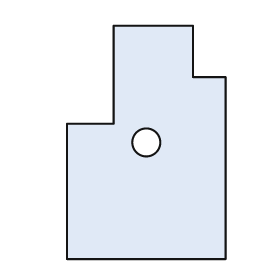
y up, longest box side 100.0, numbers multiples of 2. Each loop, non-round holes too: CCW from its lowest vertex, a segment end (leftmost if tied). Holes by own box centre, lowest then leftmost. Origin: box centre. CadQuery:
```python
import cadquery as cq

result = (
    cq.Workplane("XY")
    .moveTo(-34.0, -50.0)
    .lineTo(34.0, -50.0)
    .lineTo(34.0, 28.0)
    .lineTo(20.0, 28.0)
    .lineTo(20.0, 50.0)
    .lineTo(-14.0, 50.0)
    .lineTo(-14.0, 8.0)
    .lineTo(-34.0, 8.0)
    .close()
    .moveTo(0.0, 0.0)
    .circle(6.0)
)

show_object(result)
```